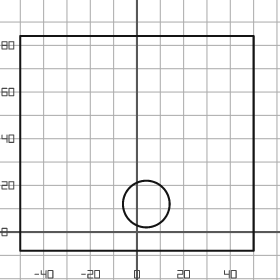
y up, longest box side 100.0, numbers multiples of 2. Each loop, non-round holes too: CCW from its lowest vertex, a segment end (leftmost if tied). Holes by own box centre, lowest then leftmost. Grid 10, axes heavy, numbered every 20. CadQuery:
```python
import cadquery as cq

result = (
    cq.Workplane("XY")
    .moveTo(-50.0, -8.0)
    .lineTo(50.0, -8.0)
    .lineTo(50.0, 84.0)
    .lineTo(-50.0, 84.0)
    .close()
    .moveTo(4.0, 12.0)
    .circle(10.0)
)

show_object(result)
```